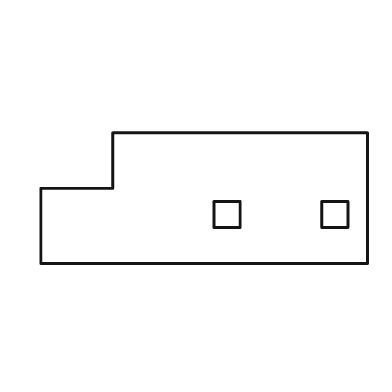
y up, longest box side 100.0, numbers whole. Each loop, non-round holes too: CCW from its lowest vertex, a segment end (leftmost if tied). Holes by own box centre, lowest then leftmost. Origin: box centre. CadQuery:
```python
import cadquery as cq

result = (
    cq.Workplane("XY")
    .moveTo(-50.0, -20.0)
    .lineTo(50.0, -20.0)
    .lineTo(50.0, 20.0)
    .lineTo(-28.0, 20.0)
    .lineTo(-28.0, 3.0)
    .lineTo(-50.0, 3.0)
    .close()
    .moveTo(3.0, -9.0)
    .lineTo(11.0, -9.0)
    .lineTo(11.0, -1.0)
    .lineTo(3.0, -1.0)
    .close()
    .moveTo(36.0, -9.0)
    .lineTo(44.0, -9.0)
    .lineTo(44.0, -1.0)
    .lineTo(36.0, -1.0)
    .close()
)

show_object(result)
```